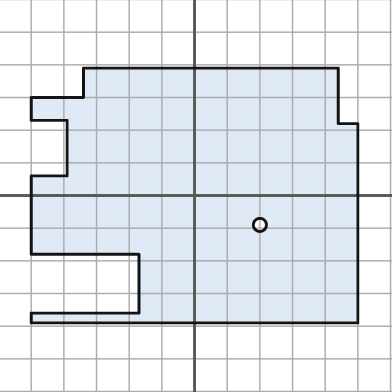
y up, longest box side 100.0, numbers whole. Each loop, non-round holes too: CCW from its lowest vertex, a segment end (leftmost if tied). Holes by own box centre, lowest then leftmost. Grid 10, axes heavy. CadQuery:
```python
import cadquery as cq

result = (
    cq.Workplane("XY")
    .moveTo(-50.0, -39.0)
    .lineTo(50.0, -39.0)
    .lineTo(50.0, 22.0)
    .lineTo(44.0, 22.0)
    .lineTo(44.0, 39.0)
    .lineTo(-34.0, 39.0)
    .lineTo(-34.0, 30.0)
    .lineTo(-50.0, 30.0)
    .lineTo(-50.0, 23.0)
    .lineTo(-39.0, 23.0)
    .lineTo(-39.0, 6.0)
    .lineTo(-50.0, 6.0)
    .lineTo(-50.0, -18.0)
    .lineTo(-17.0, -18.0)
    .lineTo(-17.0, -36.0)
    .lineTo(-50.0, -36.0)
    .close()
    .moveTo(20.0, -9.0)
    .circle(2.0)
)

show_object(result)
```